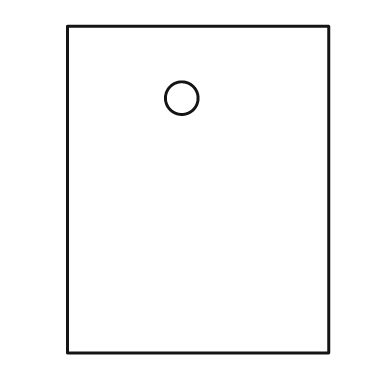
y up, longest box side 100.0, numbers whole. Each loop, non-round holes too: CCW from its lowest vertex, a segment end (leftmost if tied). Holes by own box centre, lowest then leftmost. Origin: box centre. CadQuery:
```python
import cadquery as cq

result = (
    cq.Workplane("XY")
    .moveTo(-40.0, -50.0)
    .lineTo(40.0, -50.0)
    .lineTo(40.0, 50.0)
    .lineTo(-40.0, 50.0)
    .close()
    .moveTo(-5.0, 28.0)
    .circle(5.0)
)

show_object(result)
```